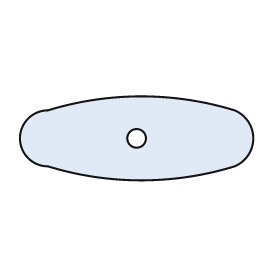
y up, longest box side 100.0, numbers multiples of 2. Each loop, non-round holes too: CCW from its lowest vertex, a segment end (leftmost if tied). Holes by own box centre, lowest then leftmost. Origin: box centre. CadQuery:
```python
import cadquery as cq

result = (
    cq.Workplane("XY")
    .moveTo(-38.0, -12.0)
    .threePointArc((2.0, -18.0), (42.0, -12.0))
    .threePointArc((50.0, 0.0), (42.0, 12.0))
    .threePointArc((2.0, 18.0), (-38.0, 12.0))
    .threePointArc((-50.0, 0.0), (-38.0, -12.0))
    .close()
    .moveTo(0.0, 0.0)
    .circle(4.0)
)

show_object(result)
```